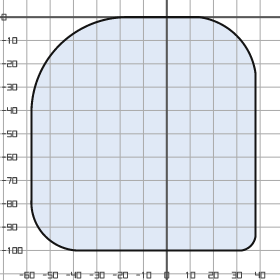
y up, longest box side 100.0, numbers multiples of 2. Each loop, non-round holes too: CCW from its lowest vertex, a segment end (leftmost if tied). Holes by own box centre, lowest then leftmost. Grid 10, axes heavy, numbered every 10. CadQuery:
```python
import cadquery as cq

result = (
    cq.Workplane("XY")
    .moveTo(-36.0, -100.0)
    .lineTo(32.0, -100.0)
    .threePointArc((36.0, -98.0), (38.0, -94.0))
    .lineTo(38.0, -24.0)
    .threePointArc((30.0, -8.0), (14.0, 0.0))
    .lineTo(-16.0, 0.0)
    .threePointArc((-46.0, -12.0), (-58.0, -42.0))
    .lineTo(-58.0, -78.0)
    .threePointArc((-52.0, -94.0), (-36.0, -100.0))
    .close()
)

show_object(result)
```